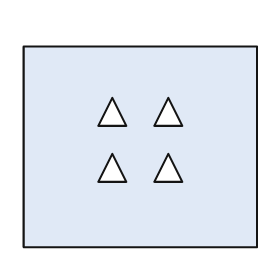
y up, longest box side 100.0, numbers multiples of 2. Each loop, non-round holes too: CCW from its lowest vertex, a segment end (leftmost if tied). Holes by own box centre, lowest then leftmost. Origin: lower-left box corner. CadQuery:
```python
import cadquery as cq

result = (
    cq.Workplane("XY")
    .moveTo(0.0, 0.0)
    .lineTo(100.0, 0.0)
    .lineTo(100.0, 86.0)
    .lineTo(0.0, 86.0)
    .close()
    .moveTo(32.0, 28.0)
    .lineTo(44.0, 28.0)
    .lineTo(38.0, 40.0)
    .close()
    .moveTo(56.0, 28.0)
    .lineTo(68.0, 28.0)
    .lineTo(62.0, 40.0)
    .close()
    .moveTo(32.0, 52.0)
    .lineTo(44.0, 52.0)
    .lineTo(38.0, 64.0)
    .close()
    .moveTo(56.0, 52.0)
    .lineTo(68.0, 52.0)
    .lineTo(62.0, 64.0)
    .close()
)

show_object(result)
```